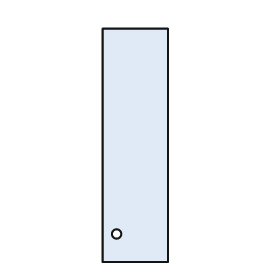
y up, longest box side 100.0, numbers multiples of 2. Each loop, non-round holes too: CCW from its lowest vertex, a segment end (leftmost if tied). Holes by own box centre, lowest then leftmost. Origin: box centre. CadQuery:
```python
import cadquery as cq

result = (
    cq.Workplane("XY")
    .moveTo(-14.0, -50.0)
    .lineTo(14.0, -50.0)
    .lineTo(14.0, 50.0)
    .lineTo(-14.0, 50.0)
    .close()
    .moveTo(-8.0, -38.0)
    .circle(2.0)
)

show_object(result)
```